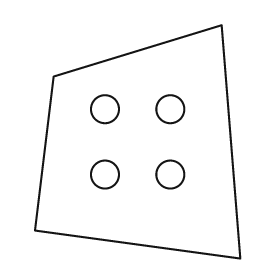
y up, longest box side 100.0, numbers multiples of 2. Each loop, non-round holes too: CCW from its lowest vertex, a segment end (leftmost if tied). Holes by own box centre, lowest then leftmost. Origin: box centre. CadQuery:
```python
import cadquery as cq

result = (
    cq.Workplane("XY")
    .moveTo(44.0, -50.0)
    .lineTo(36.0, 50.0)
    .lineTo(-36.0, 28.0)
    .lineTo(-44.0, -38.0)
    .close()
    .moveTo(-14.0, -14.0)
    .circle(6.0)
    .moveTo(14.0, -14.0)
    .circle(6.0)
    .moveTo(-14.0, 14.0)
    .circle(6.0)
    .moveTo(14.0, 14.0)
    .circle(6.0)
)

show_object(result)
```